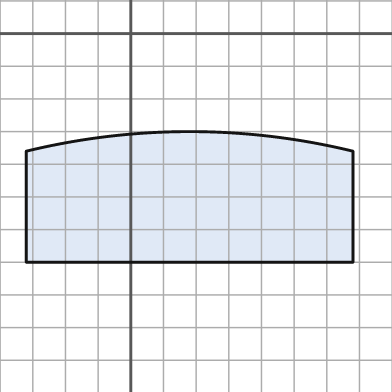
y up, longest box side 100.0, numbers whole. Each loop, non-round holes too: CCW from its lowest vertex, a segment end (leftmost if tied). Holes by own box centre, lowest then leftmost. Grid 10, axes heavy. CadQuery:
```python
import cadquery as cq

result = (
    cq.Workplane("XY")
    .moveTo(-32.0, -70.0)
    .lineTo(68.0, -70.0)
    .lineTo(68.0, -36.0)
    .threePointArc((18.0, -30.0), (-32.0, -36.0))
    .close()
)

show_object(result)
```